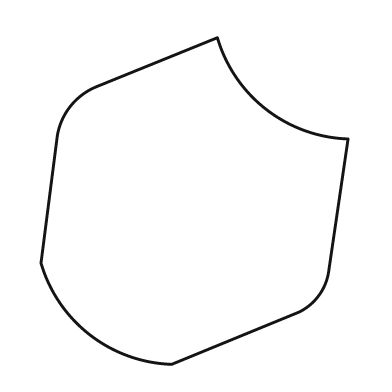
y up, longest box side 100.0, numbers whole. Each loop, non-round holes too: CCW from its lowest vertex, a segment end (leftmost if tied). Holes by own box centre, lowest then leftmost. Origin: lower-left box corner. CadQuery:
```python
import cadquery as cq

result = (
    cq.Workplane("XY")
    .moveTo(40.0, 0.0)
    .lineTo(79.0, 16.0)
    .threePointArc((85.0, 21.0), (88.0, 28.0))
    .lineTo(94.0, 69.0)
    .threePointArc((69.0, 78.0), (54.0, 100.0))
    .lineTo(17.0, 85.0)
    .threePointArc((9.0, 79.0), (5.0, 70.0))
    .lineTo(0.0, 31.0)
    .threePointArc((15.0, 9.0), (40.0, 0.0))
    .close()
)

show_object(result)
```